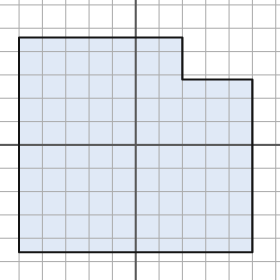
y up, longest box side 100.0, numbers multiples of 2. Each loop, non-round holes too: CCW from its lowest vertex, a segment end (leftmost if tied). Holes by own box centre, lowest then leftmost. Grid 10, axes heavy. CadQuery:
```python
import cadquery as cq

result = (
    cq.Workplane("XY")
    .moveTo(-50.0, -46.0)
    .lineTo(50.0, -46.0)
    .lineTo(50.0, 28.0)
    .lineTo(20.0, 28.0)
    .lineTo(20.0, 46.0)
    .lineTo(-50.0, 46.0)
    .close()
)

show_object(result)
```